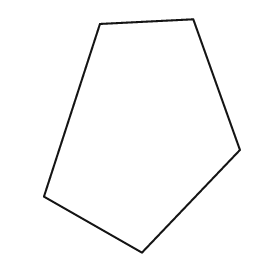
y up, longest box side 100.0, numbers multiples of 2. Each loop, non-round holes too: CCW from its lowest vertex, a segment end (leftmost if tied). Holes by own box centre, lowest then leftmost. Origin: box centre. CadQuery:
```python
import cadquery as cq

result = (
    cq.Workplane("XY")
    .moveTo(0.0, -50.0)
    .lineTo(42.0, -6.0)
    .lineTo(22.0, 50.0)
    .lineTo(-18.0, 48.0)
    .lineTo(-42.0, -26.0)
    .close()
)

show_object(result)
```